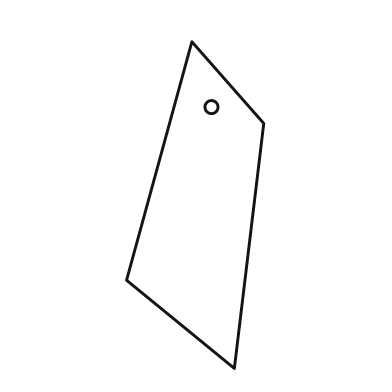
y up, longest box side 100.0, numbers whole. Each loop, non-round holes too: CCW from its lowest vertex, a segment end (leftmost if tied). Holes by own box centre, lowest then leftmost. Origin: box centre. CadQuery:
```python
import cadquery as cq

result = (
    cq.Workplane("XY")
    .moveTo(12.0, -50.0)
    .lineTo(21.0, 25.0)
    .lineTo(-1.0, 50.0)
    .lineTo(-21.0, -23.0)
    .close()
    .moveTo(5.0, 30.0)
    .circle(2.0)
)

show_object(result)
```